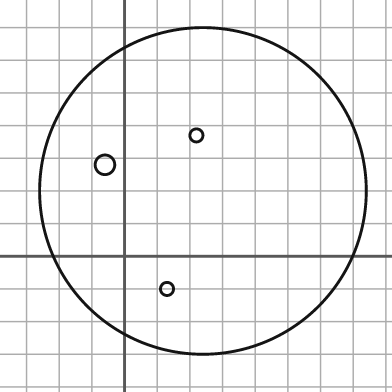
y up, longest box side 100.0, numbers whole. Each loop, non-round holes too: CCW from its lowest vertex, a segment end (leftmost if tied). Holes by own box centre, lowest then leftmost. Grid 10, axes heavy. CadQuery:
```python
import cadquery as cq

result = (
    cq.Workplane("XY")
    .moveTo(24.0, 20.0)
    .circle(50.0)
    .moveTo(13.0, -10.0)
    .circle(2.0)
    .moveTo(-6.0, 28.0)
    .circle(3.0)
    .moveTo(22.0, 37.0)
    .circle(2.0)
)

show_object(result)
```